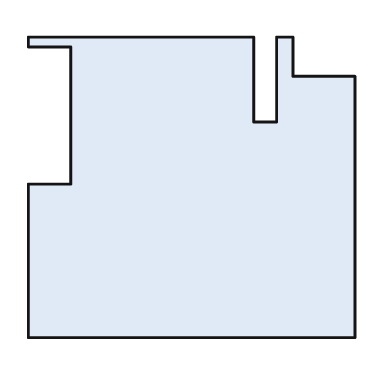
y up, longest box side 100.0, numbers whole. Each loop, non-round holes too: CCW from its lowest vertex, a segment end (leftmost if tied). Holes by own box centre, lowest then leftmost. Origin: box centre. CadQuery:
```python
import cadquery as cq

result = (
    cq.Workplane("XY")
    .moveTo(-50.0, -46.0)
    .lineTo(50.0, -46.0)
    .lineTo(50.0, 34.0)
    .lineTo(31.0, 34.0)
    .lineTo(31.0, 46.0)
    .lineTo(26.0, 46.0)
    .lineTo(26.0, 20.0)
    .lineTo(19.0, 20.0)
    .lineTo(19.0, 46.0)
    .lineTo(-50.0, 46.0)
    .lineTo(-50.0, 43.0)
    .lineTo(-37.0, 43.0)
    .lineTo(-37.0, 1.0)
    .lineTo(-50.0, 1.0)
    .close()
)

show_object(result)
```